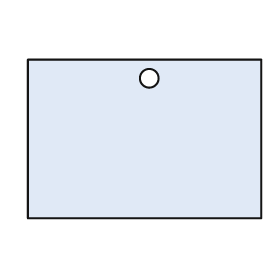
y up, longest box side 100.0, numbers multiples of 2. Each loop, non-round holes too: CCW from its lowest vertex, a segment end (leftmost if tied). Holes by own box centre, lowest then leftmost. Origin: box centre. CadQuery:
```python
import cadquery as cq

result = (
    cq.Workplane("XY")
    .moveTo(-50.0, -34.0)
    .lineTo(50.0, -34.0)
    .lineTo(50.0, 34.0)
    .lineTo(-50.0, 34.0)
    .close()
    .moveTo(2.0, 26.0)
    .circle(4.0)
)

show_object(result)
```